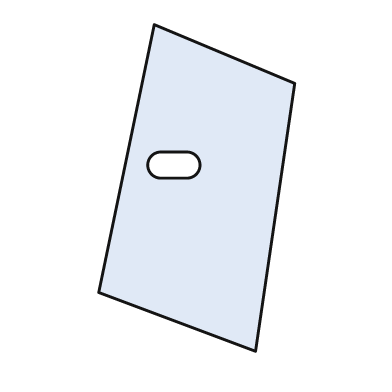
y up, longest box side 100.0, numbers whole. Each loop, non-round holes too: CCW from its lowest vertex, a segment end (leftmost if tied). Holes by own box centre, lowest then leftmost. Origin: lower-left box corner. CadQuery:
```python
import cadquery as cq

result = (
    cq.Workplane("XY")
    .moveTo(48.0, 0.0)
    .lineTo(60.0, 82.0)
    .lineTo(17.0, 100.0)
    .lineTo(0.0, 18.0)
    .close()
    .moveTo(19.0, 53.0)
    .lineTo(27.0, 53.0)
    .threePointArc((31.0, 57.0), (27.0, 61.0))
    .lineTo(19.0, 61.0)
    .threePointArc((15.0, 57.0), (19.0, 53.0))
    .close()
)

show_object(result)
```